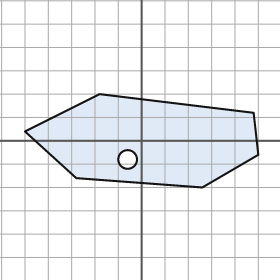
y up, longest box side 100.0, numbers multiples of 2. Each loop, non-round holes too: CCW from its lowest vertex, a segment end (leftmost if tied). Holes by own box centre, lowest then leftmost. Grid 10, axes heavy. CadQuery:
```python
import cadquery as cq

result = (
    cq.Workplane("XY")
    .moveTo(26.0, -20.0)
    .lineTo(50.0, -6.0)
    .lineTo(48.0, 12.0)
    .lineTo(-18.0, 20.0)
    .lineTo(-50.0, 4.0)
    .lineTo(-28.0, -16.0)
    .close()
    .moveTo(-6.0, -8.0)
    .circle(4.0)
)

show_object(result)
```